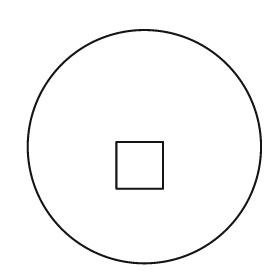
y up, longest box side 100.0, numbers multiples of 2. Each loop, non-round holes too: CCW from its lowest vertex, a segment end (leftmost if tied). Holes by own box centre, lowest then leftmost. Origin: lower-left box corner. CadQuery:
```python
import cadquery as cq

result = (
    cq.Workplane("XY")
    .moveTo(50.0, 50.0)
    .circle(50.0)
    .moveTo(38.0, 32.0)
    .lineTo(58.0, 32.0)
    .lineTo(58.0, 52.0)
    .lineTo(38.0, 52.0)
    .close()
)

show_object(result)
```